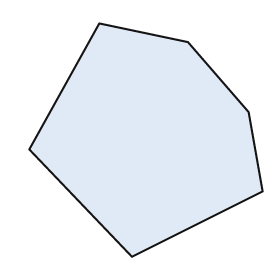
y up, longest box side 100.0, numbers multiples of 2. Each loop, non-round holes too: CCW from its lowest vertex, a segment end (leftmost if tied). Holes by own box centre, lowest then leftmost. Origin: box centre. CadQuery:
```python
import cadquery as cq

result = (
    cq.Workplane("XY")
    .moveTo(-6.0, -50.0)
    .lineTo(50.0, -22.0)
    .lineTo(44.0, 12.0)
    .lineTo(18.0, 42.0)
    .lineTo(-20.0, 50.0)
    .lineTo(-50.0, -4.0)
    .close()
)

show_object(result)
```